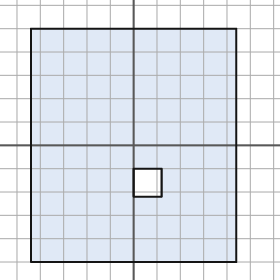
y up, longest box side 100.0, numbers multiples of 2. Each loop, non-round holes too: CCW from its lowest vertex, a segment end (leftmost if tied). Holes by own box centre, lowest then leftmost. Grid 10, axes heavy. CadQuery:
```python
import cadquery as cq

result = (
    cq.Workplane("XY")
    .moveTo(-44.0, -50.0)
    .lineTo(44.0, -50.0)
    .lineTo(44.0, 50.0)
    .lineTo(-44.0, 50.0)
    .close()
    .moveTo(0.0, -22.0)
    .lineTo(12.0, -22.0)
    .lineTo(12.0, -10.0)
    .lineTo(0.0, -10.0)
    .close()
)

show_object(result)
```